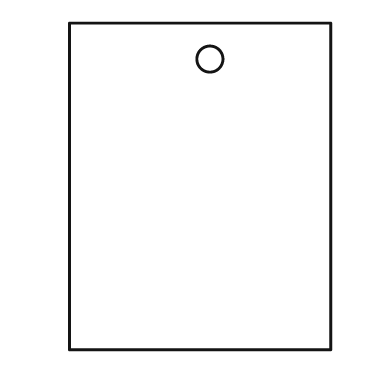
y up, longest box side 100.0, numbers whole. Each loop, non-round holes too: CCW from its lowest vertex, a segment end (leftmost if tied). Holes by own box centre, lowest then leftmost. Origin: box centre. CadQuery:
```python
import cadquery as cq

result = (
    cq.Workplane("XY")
    .moveTo(-40.0, -50.0)
    .lineTo(40.0, -50.0)
    .lineTo(40.0, 50.0)
    .lineTo(-40.0, 50.0)
    .close()
    .moveTo(3.0, 39.0)
    .circle(4.0)
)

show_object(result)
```